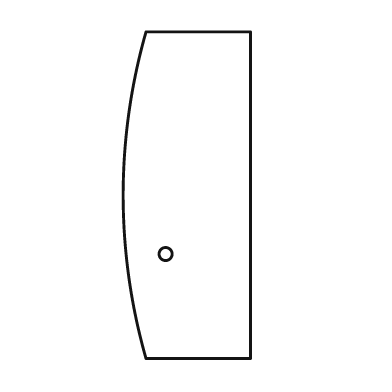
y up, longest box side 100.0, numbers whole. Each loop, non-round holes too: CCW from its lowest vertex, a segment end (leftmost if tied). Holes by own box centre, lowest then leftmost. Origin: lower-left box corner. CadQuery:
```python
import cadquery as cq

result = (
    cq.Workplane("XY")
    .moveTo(7.0, 0.0)
    .lineTo(39.0, 0.0)
    .lineTo(39.0, 100.0)
    .lineTo(7.0, 100.0)
    .threePointArc((0.0, 50.0), (7.0, 0.0))
    .close()
    .moveTo(13.0, 32.0)
    .circle(2.0)
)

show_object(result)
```